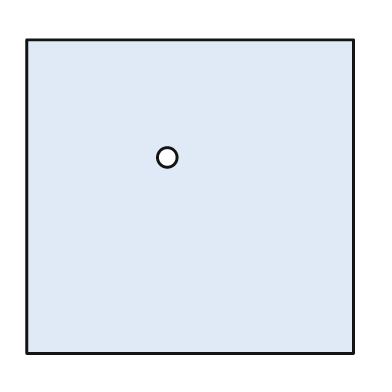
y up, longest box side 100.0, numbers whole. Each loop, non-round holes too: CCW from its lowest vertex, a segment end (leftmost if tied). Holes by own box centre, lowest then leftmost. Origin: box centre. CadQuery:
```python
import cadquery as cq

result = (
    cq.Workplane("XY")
    .moveTo(-50.0, -48.0)
    .lineTo(50.0, -48.0)
    .lineTo(50.0, 48.0)
    .lineTo(-50.0, 48.0)
    .close()
    .moveTo(-7.0, 12.0)
    .circle(3.0)
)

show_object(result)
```